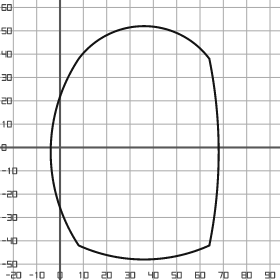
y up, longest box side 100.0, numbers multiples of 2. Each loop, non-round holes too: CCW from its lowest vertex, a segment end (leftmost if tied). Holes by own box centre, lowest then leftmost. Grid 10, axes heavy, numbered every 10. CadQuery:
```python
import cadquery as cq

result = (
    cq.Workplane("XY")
    .moveTo(8.0, -42.0)
    .threePointArc((36.0, -48.0), (64.0, -42.0))
    .threePointArc((68.0, -2.0), (64.0, 38.0))
    .threePointArc((36.0, 52.0), (8.0, 38.0))
    .threePointArc((-4.0, -2.0), (8.0, -42.0))
    .close()
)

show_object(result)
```